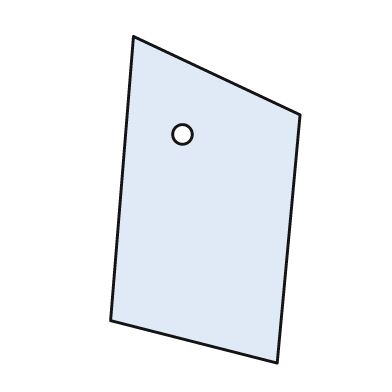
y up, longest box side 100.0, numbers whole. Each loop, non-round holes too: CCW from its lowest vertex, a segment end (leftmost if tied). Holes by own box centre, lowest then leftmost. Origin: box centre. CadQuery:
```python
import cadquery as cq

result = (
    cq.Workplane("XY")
    .moveTo(22.0, -50.0)
    .lineTo(29.0, 26.0)
    .lineTo(-22.0, 50.0)
    .lineTo(-29.0, -37.0)
    .close()
    .moveTo(-7.0, 20.0)
    .circle(3.0)
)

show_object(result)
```